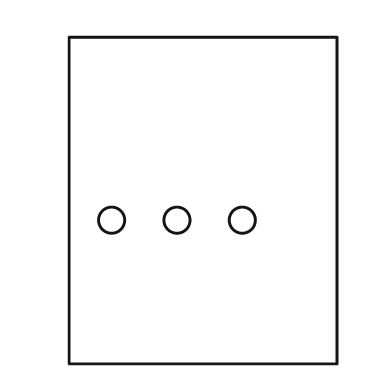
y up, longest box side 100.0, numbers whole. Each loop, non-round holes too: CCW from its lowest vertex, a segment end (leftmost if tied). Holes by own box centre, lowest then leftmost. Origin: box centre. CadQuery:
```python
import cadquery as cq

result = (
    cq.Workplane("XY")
    .moveTo(-41.0, -50.0)
    .lineTo(41.0, -50.0)
    .lineTo(41.0, 50.0)
    .lineTo(-41.0, 50.0)
    .close()
    .moveTo(-28.0, -6.0)
    .circle(4.0)
    .moveTo(-8.0, -6.0)
    .circle(4.0)
    .moveTo(12.0, -6.0)
    .circle(4.0)
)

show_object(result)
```